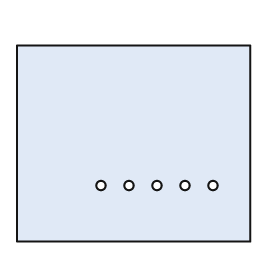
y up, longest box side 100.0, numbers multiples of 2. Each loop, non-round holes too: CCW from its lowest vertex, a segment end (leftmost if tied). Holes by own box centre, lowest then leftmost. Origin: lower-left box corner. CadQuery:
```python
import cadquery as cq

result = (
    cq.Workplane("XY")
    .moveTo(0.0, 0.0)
    .lineTo(100.0, 0.0)
    .lineTo(100.0, 84.0)
    .lineTo(0.0, 84.0)
    .close()
    .moveTo(36.0, 24.0)
    .circle(2.0)
    .moveTo(48.0, 24.0)
    .circle(2.0)
    .moveTo(60.0, 24.0)
    .circle(2.0)
    .moveTo(72.0, 24.0)
    .circle(2.0)
    .moveTo(84.0, 24.0)
    .circle(2.0)
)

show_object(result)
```